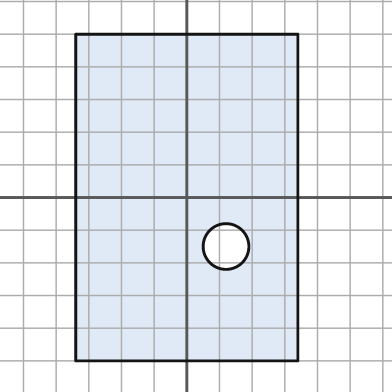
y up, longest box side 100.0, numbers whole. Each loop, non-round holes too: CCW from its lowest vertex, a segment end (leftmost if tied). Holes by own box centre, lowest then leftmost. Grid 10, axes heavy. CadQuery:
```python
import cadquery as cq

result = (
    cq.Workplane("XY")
    .moveTo(-34.0, -50.0)
    .lineTo(34.0, -50.0)
    .lineTo(34.0, 50.0)
    .lineTo(-34.0, 50.0)
    .close()
    .moveTo(12.0, -15.0)
    .circle(7.0)
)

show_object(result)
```